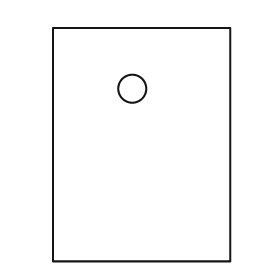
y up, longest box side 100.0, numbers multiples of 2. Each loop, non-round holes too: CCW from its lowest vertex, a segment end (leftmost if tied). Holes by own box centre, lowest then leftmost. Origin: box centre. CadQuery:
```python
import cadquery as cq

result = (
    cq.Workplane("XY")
    .moveTo(-38.0, -50.0)
    .lineTo(38.0, -50.0)
    .lineTo(38.0, 50.0)
    .lineTo(-38.0, 50.0)
    .close()
    .moveTo(-4.0, 24.0)
    .circle(6.0)
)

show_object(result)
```